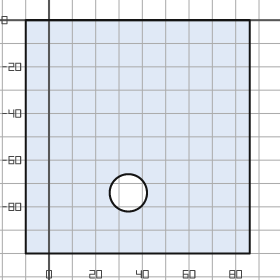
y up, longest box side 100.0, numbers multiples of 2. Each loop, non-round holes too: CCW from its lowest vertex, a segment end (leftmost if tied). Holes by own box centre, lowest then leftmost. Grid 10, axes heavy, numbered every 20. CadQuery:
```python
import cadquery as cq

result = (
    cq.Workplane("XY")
    .moveTo(-10.0, -100.0)
    .lineTo(86.0, -100.0)
    .lineTo(86.0, 0.0)
    .lineTo(-10.0, 0.0)
    .close()
    .moveTo(34.0, -74.0)
    .circle(8.0)
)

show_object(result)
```